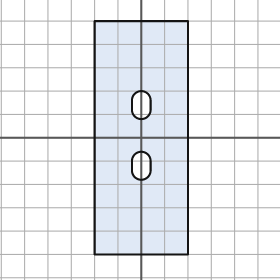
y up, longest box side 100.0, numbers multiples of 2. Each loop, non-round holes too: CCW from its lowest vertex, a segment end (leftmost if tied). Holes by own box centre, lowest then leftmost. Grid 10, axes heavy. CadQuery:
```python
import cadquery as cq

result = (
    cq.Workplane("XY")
    .moveTo(-20.0, -50.0)
    .lineTo(20.0, -50.0)
    .lineTo(20.0, 50.0)
    .lineTo(-20.0, 50.0)
    .close()
    .moveTo(-4.0, -14.0)
    .threePointArc((0.0, -18.0), (4.0, -14.0))
    .lineTo(4.0, -10.0)
    .threePointArc((0.0, -6.0), (-4.0, -10.0))
    .close()
    .moveTo(-4.0, 12.0)
    .threePointArc((0.0, 8.0), (4.0, 12.0))
    .lineTo(4.0, 16.0)
    .threePointArc((0.0, 20.0), (-4.0, 16.0))
    .close()
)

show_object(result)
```